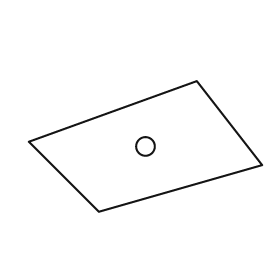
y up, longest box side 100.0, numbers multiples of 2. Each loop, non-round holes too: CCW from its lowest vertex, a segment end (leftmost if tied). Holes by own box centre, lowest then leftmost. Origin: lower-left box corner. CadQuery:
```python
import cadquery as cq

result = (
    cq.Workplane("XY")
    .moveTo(30.0, 0.0)
    .lineTo(100.0, 20.0)
    .lineTo(72.0, 56.0)
    .lineTo(0.0, 30.0)
    .close()
    .moveTo(50.0, 28.0)
    .circle(4.0)
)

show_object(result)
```